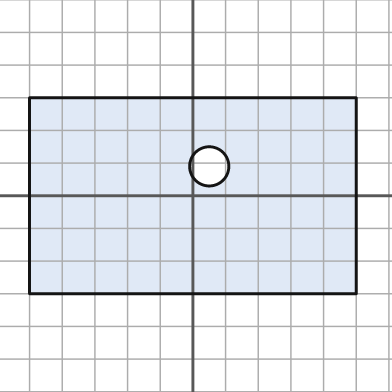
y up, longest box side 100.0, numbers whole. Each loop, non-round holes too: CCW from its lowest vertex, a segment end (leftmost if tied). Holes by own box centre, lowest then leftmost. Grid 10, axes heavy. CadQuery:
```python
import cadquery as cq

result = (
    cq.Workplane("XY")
    .moveTo(-50.0, -30.0)
    .lineTo(50.0, -30.0)
    .lineTo(50.0, 30.0)
    .lineTo(-50.0, 30.0)
    .close()
    .moveTo(5.0, 9.0)
    .circle(6.0)
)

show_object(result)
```